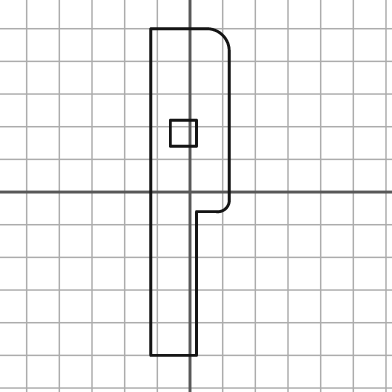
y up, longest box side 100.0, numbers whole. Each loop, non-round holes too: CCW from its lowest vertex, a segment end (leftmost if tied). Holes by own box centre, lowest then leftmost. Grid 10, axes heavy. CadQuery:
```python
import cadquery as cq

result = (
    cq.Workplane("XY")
    .moveTo(-12.0, -50.0)
    .lineTo(2.0, -50.0)
    .lineTo(2.0, -6.0)
    .lineTo(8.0, -6.0)
    .threePointArc((11.0, -5.0), (12.0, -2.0))
    .lineTo(12.0, 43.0)
    .threePointArc((10.0, 48.0), (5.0, 50.0))
    .lineTo(-12.0, 50.0)
    .close()
    .moveTo(-6.0, 14.0)
    .lineTo(2.0, 14.0)
    .lineTo(2.0, 22.0)
    .lineTo(-6.0, 22.0)
    .close()
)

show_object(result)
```